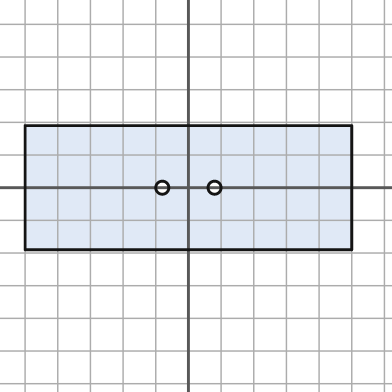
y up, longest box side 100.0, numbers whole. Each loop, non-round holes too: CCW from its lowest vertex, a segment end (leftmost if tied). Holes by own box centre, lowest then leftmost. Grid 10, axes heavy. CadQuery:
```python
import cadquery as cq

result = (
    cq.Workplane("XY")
    .moveTo(-50.0, -19.0)
    .lineTo(50.0, -19.0)
    .lineTo(50.0, 19.0)
    .lineTo(-50.0, 19.0)
    .close()
    .moveTo(-8.0, 0.0)
    .circle(2.0)
    .moveTo(8.0, 0.0)
    .circle(2.0)
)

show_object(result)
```